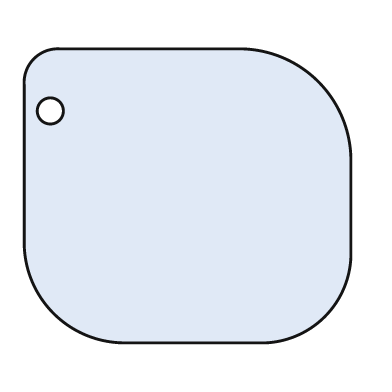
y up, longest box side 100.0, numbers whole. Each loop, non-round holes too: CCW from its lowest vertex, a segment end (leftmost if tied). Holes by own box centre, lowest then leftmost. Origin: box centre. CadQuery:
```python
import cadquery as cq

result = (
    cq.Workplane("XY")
    .moveTo(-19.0, -45.0)
    .lineTo(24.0, -45.0)
    .threePointArc((42.0, -37.0), (50.0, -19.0))
    .lineTo(50.0, 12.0)
    .threePointArc((40.0, 35.0), (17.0, 45.0))
    .lineTo(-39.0, 45.0)
    .threePointArc((-47.0, 42.0), (-50.0, 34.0))
    .lineTo(-50.0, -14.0)
    .threePointArc((-41.0, -36.0), (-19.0, -45.0))
    .close()
    .moveTo(-42.0, 26.0)
    .circle(4.0)
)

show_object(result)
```